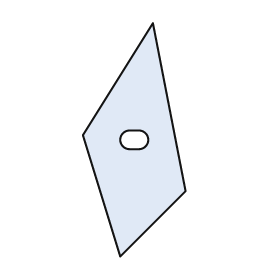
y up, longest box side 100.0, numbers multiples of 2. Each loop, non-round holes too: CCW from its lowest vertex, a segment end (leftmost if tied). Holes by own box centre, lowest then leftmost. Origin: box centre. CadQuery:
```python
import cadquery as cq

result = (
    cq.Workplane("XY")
    .moveTo(-6.0, -50.0)
    .lineTo(22.0, -22.0)
    .lineTo(8.0, 50.0)
    .lineTo(-22.0, 2.0)
    .close()
    .moveTo(-2.0, -4.0)
    .lineTo(2.0, -4.0)
    .threePointArc((6.0, 0.0), (2.0, 4.0))
    .lineTo(-2.0, 4.0)
    .threePointArc((-6.0, 0.0), (-2.0, -4.0))
    .close()
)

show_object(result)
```